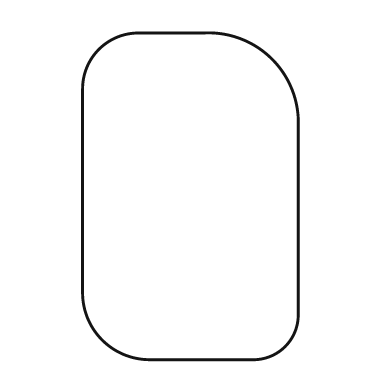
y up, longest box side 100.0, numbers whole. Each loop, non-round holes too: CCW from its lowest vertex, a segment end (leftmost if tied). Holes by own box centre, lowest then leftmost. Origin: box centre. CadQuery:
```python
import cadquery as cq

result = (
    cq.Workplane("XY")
    .moveTo(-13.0, -50.0)
    .lineTo(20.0, -50.0)
    .threePointArc((29.0, -46.0), (33.0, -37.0))
    .lineTo(33.0, 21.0)
    .threePointArc((25.0, 42.0), (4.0, 50.0))
    .lineTo(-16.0, 50.0)
    .threePointArc((-28.0, 45.0), (-33.0, 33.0))
    .lineTo(-33.0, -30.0)
    .threePointArc((-27.0, -44.0), (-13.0, -50.0))
    .close()
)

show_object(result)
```